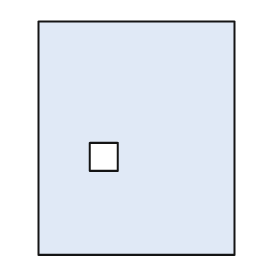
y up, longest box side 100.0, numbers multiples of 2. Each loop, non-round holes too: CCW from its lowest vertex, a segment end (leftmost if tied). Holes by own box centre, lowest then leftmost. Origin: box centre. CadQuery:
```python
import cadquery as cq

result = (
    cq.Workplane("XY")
    .moveTo(-42.0, -50.0)
    .lineTo(42.0, -50.0)
    .lineTo(42.0, 50.0)
    .lineTo(-42.0, 50.0)
    .close()
    .moveTo(-20.0, -14.0)
    .lineTo(-8.0, -14.0)
    .lineTo(-8.0, -2.0)
    .lineTo(-20.0, -2.0)
    .close()
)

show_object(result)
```